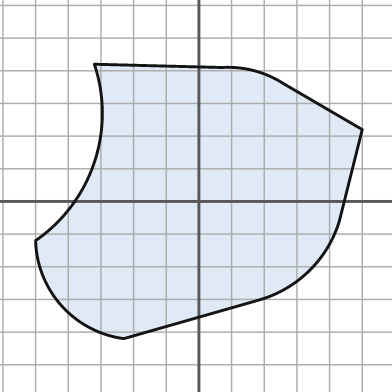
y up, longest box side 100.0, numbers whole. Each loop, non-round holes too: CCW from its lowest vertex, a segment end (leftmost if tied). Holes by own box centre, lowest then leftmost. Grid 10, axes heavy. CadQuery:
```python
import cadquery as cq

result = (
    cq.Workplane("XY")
    .moveTo(-23.0, -42.0)
    .lineTo(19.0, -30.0)
    .threePointArc((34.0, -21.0), (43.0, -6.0))
    .lineTo(50.0, 22.0)
    .lineTo(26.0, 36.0)
    .threePointArc((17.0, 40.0), (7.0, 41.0))
    .lineTo(-32.0, 42.0)
    .threePointArc((-32.0, 12.0), (-50.0, -12.0))
    .threePointArc((-42.0, -32.0), (-23.0, -42.0))
    .close()
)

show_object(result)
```